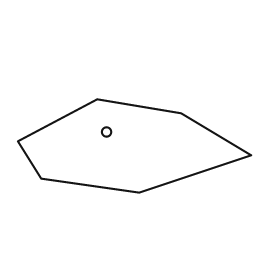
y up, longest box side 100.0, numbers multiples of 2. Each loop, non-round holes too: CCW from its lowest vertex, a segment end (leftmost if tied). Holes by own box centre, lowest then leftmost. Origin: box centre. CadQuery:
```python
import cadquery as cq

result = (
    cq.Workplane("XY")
    .moveTo(2.0, -20.0)
    .lineTo(50.0, -4.0)
    .lineTo(20.0, 14.0)
    .lineTo(-16.0, 20.0)
    .lineTo(-50.0, 2.0)
    .lineTo(-40.0, -14.0)
    .close()
    .moveTo(-12.0, 6.0)
    .circle(2.0)
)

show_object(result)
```